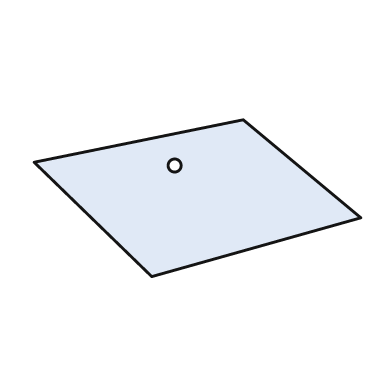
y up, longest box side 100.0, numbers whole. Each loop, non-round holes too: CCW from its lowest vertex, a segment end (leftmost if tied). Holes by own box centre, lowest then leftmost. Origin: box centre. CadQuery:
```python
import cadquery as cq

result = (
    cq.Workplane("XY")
    .moveTo(-14.0, -24.0)
    .lineTo(50.0, -6.0)
    .lineTo(14.0, 24.0)
    .lineTo(-50.0, 11.0)
    .close()
    .moveTo(-7.0, 10.0)
    .circle(2.0)
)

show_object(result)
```